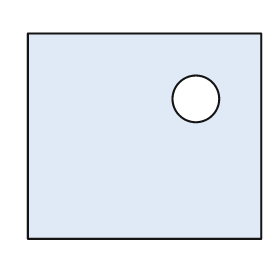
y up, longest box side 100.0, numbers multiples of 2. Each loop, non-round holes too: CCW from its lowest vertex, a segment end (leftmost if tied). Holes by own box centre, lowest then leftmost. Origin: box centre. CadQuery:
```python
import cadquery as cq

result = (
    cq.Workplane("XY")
    .moveTo(-50.0, -44.0)
    .lineTo(50.0, -44.0)
    .lineTo(50.0, 44.0)
    .lineTo(-50.0, 44.0)
    .close()
    .moveTo(22.0, 16.0)
    .circle(10.0)
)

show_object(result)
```